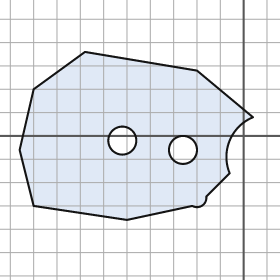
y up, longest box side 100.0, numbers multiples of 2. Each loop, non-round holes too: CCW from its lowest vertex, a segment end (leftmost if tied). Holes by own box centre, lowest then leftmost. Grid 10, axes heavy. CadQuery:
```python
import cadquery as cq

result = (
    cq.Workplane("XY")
    .moveTo(-50.0, -36.0)
    .lineTo(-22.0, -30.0)
    .threePointArc((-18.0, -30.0), (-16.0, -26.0))
    .lineTo(-6.0, -16.0)
    .threePointArc((-6.0, -2.0), (4.0, 8.0))
    .lineTo(-20.0, 28.0)
    .lineTo(-68.0, 36.0)
    .lineTo(-90.0, 20.0)
    .lineTo(-96.0, -6.0)
    .lineTo(-90.0, -30.0)
    .close()
    .moveTo(-26.0, -6.0)
    .circle(6.0)
    .moveTo(-52.0, -2.0)
    .circle(6.0)
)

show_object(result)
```